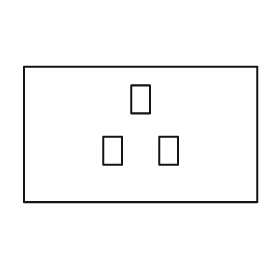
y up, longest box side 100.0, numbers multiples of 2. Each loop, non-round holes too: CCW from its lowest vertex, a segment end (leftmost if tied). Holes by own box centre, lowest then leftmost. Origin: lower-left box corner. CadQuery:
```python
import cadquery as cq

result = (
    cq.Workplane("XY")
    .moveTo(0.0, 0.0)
    .lineTo(100.0, 0.0)
    .lineTo(100.0, 58.0)
    .lineTo(0.0, 58.0)
    .close()
    .moveTo(34.0, 16.0)
    .lineTo(42.0, 16.0)
    .lineTo(42.0, 28.0)
    .lineTo(34.0, 28.0)
    .close()
    .moveTo(58.0, 16.0)
    .lineTo(66.0, 16.0)
    .lineTo(66.0, 28.0)
    .lineTo(58.0, 28.0)
    .close()
    .moveTo(46.0, 38.0)
    .lineTo(54.0, 38.0)
    .lineTo(54.0, 50.0)
    .lineTo(46.0, 50.0)
    .close()
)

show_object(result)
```